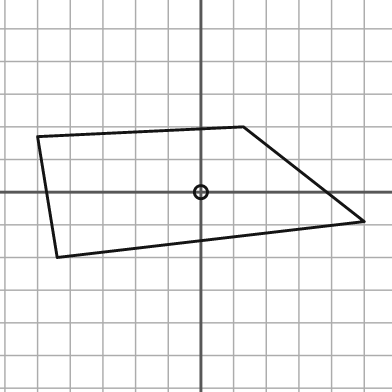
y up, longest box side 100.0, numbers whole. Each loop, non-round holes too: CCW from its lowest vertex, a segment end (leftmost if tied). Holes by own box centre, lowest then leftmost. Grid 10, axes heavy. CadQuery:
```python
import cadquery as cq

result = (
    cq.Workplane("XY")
    .moveTo(-44.0, -20.0)
    .lineTo(50.0, -9.0)
    .lineTo(13.0, 20.0)
    .lineTo(-50.0, 17.0)
    .close()
    .moveTo(0.0, 0.0)
    .circle(2.0)
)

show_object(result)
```